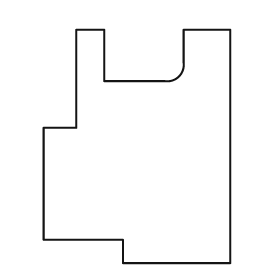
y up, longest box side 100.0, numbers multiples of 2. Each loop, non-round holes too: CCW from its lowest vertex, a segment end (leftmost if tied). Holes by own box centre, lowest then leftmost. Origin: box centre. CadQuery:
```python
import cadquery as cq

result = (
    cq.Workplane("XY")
    .moveTo(-6.0, -50.0)
    .lineTo(40.0, -50.0)
    .lineTo(40.0, 50.0)
    .lineTo(20.0, 50.0)
    .lineTo(20.0, 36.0)
    .threePointArc((18.0, 30.0), (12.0, 28.0))
    .lineTo(-14.0, 28.0)
    .lineTo(-14.0, 50.0)
    .lineTo(-26.0, 50.0)
    .lineTo(-26.0, 8.0)
    .lineTo(-40.0, 8.0)
    .lineTo(-40.0, -40.0)
    .lineTo(-6.0, -40.0)
    .close()
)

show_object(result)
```